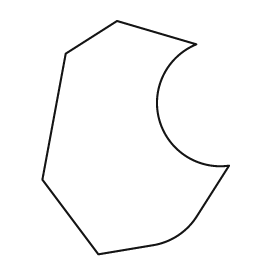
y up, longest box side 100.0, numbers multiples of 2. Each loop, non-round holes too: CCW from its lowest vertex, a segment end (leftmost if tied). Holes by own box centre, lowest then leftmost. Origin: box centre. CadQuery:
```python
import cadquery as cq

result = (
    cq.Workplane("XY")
    .moveTo(-16.0, -50.0)
    .lineTo(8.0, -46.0)
    .threePointArc((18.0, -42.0), (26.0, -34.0))
    .lineTo(40.0, -12.0)
    .threePointArc((10.0, 8.0), (26.0, 40.0))
    .lineTo(-8.0, 50.0)
    .lineTo(-30.0, 36.0)
    .lineTo(-40.0, -18.0)
    .close()
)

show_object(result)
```